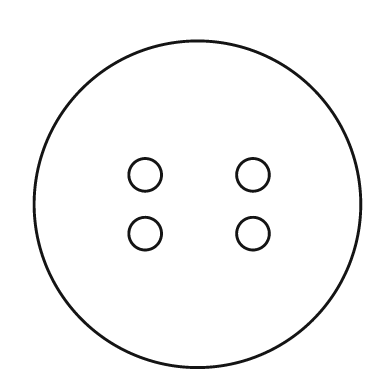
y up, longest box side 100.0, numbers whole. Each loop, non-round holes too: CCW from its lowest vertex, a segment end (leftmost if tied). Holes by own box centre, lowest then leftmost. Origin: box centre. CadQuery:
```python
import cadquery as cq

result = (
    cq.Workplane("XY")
    .moveTo(0.0, 0.0)
    .circle(50.0)
    .moveTo(-16.0, -9.0)
    .circle(5.0)
    .moveTo(17.0, -9.0)
    .circle(5.0)
    .moveTo(-16.0, 9.0)
    .circle(5.0)
    .moveTo(17.0, 9.0)
    .circle(5.0)
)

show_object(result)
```